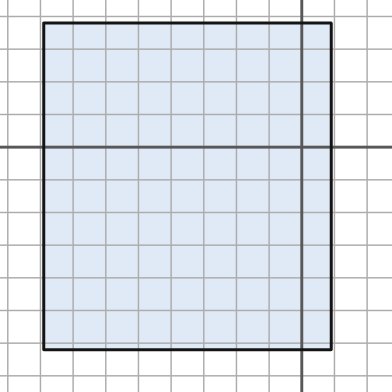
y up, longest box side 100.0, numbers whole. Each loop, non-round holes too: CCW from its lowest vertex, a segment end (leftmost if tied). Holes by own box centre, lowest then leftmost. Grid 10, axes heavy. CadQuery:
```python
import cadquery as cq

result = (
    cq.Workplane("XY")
    .moveTo(-79.0, -62.0)
    .lineTo(9.0, -62.0)
    .lineTo(9.0, 38.0)
    .lineTo(-79.0, 38.0)
    .close()
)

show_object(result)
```